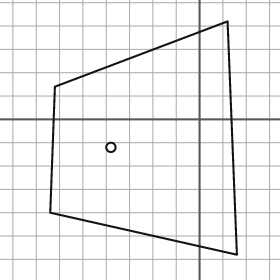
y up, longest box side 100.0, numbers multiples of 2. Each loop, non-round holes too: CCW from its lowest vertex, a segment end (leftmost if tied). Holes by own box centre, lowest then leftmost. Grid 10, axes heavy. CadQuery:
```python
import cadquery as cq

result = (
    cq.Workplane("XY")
    .moveTo(16.0, -58.0)
    .lineTo(12.0, 42.0)
    .lineTo(-62.0, 14.0)
    .lineTo(-64.0, -40.0)
    .close()
    .moveTo(-38.0, -12.0)
    .circle(2.0)
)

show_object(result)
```